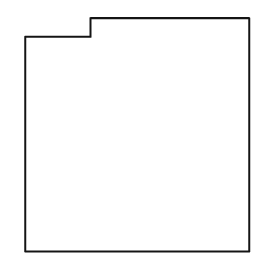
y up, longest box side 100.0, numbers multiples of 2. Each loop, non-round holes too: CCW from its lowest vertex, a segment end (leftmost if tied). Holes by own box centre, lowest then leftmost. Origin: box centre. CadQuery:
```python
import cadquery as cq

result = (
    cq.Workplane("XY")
    .moveTo(-48.0, -50.0)
    .lineTo(48.0, -50.0)
    .lineTo(48.0, 50.0)
    .lineTo(-20.0, 50.0)
    .lineTo(-20.0, 42.0)
    .lineTo(-48.0, 42.0)
    .close()
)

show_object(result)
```